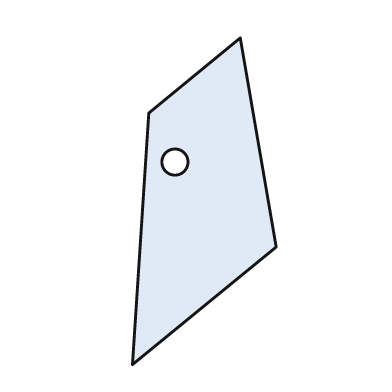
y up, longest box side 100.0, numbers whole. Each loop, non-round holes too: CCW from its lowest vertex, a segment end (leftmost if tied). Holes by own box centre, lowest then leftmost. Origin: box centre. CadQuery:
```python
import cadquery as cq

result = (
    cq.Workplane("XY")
    .moveTo(-22.0, -50.0)
    .lineTo(22.0, -14.0)
    .lineTo(11.0, 50.0)
    .lineTo(-17.0, 27.0)
    .close()
    .moveTo(-9.0, 12.0)
    .circle(4.0)
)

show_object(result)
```